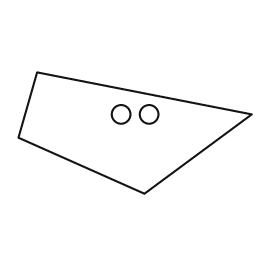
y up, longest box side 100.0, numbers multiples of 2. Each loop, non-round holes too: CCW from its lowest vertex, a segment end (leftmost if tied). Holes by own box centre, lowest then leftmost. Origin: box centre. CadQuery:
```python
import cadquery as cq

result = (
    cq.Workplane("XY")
    .moveTo(4.0, -26.0)
    .lineTo(50.0, 8.0)
    .lineTo(-42.0, 26.0)
    .lineTo(-50.0, -2.0)
    .close()
    .moveTo(-6.0, 8.0)
    .circle(4.0)
    .moveTo(6.0, 8.0)
    .circle(4.0)
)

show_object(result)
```